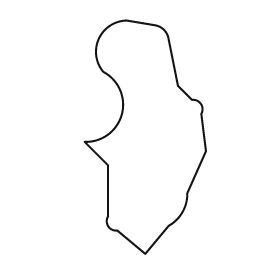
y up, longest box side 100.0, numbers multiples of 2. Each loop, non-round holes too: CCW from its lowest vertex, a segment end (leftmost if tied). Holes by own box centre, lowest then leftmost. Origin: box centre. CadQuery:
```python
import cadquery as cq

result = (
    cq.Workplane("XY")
    .moveTo(0.0, -50.0)
    .lineTo(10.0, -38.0)
    .threePointArc((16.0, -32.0), (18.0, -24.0))
    .lineTo(26.0, -6.0)
    .lineTo(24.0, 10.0)
    .threePointArc((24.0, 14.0), (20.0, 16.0))
    .lineTo(14.0, 22.0)
    .lineTo(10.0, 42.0)
    .threePointArc((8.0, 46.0), (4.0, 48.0))
    .lineTo(-8.0, 50.0)
    .threePointArc((-20.0, 42.0), (-18.0, 28.0))
    .threePointArc((-10.0, 10.0), (-26.0, -2.0))
    .lineTo(-16.0, -12.0)
    .lineTo(-16.0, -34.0)
    .threePointArc((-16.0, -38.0), (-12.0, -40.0))
    .close()
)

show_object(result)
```